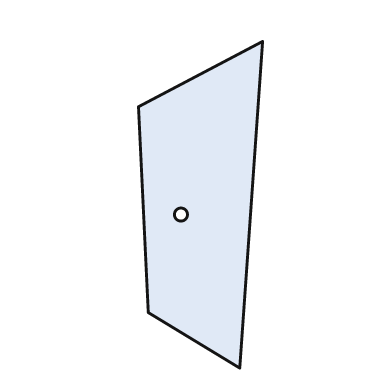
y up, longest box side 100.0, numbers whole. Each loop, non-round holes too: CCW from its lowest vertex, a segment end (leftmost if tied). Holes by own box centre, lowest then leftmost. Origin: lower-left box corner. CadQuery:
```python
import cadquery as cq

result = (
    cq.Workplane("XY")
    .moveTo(31.0, 0.0)
    .lineTo(38.0, 100.0)
    .lineTo(0.0, 80.0)
    .lineTo(3.0, 17.0)
    .close()
    .moveTo(13.0, 47.0)
    .circle(2.0)
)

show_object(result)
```